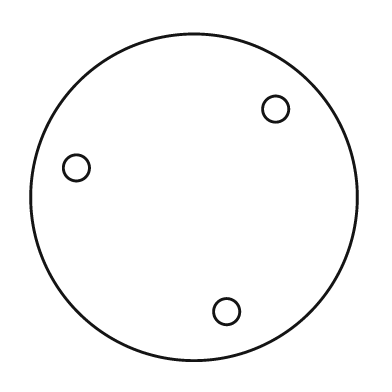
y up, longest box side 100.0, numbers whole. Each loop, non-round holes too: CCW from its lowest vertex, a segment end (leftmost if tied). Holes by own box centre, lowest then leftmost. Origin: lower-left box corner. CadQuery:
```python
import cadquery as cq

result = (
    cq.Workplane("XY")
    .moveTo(50.0, 50.0)
    .circle(50.0)
    .moveTo(60.0, 15.0)
    .circle(4.0)
    .moveTo(14.0, 59.0)
    .circle(4.0)
    .moveTo(75.0, 77.0)
    .circle(4.0)
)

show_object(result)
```